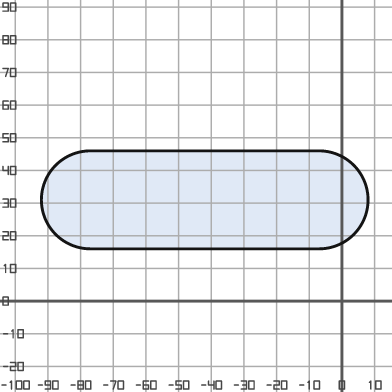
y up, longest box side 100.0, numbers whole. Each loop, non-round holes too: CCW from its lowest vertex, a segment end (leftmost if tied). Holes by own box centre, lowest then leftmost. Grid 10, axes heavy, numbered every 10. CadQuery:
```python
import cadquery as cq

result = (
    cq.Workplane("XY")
    .moveTo(-77.0, 16.0)
    .lineTo(-7.0, 16.0)
    .threePointArc((8.0, 31.0), (-7.0, 46.0))
    .lineTo(-77.0, 46.0)
    .threePointArc((-92.0, 31.0), (-77.0, 16.0))
    .close()
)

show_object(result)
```